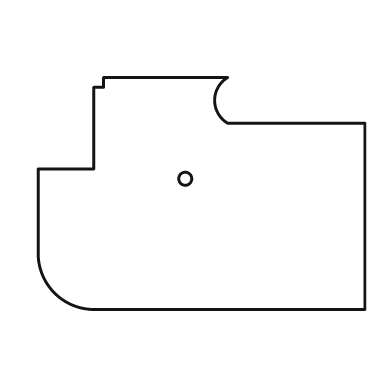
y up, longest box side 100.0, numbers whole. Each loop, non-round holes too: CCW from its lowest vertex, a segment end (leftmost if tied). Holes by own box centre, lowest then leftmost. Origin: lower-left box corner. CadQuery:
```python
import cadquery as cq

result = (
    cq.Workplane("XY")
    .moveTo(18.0, 0.0)
    .lineTo(100.0, 0.0)
    .lineTo(100.0, 57.0)
    .lineTo(58.0, 57.0)
    .threePointArc((54.0, 64.0), (58.0, 71.0))
    .lineTo(20.0, 71.0)
    .lineTo(20.0, 68.0)
    .lineTo(17.0, 68.0)
    .lineTo(17.0, 43.0)
    .lineTo(0.0, 43.0)
    .lineTo(0.0, 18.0)
    .threePointArc((5.0, 5.0), (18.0, 0.0))
    .close()
    .moveTo(45.0, 40.0)
    .circle(2.0)
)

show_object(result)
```